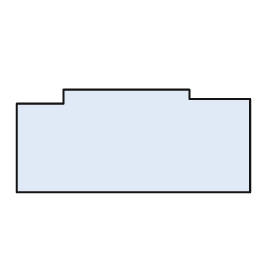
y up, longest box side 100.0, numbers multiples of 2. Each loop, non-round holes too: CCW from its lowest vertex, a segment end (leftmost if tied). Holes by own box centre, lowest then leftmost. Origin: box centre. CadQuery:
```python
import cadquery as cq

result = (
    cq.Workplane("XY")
    .moveTo(-50.0, -22.0)
    .lineTo(50.0, -22.0)
    .lineTo(50.0, 18.0)
    .lineTo(24.0, 18.0)
    .lineTo(24.0, 22.0)
    .lineTo(-30.0, 22.0)
    .lineTo(-30.0, 16.0)
    .lineTo(-50.0, 16.0)
    .close()
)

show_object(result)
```